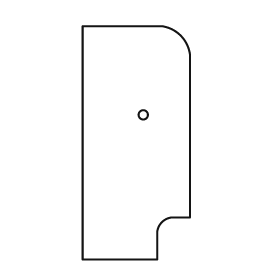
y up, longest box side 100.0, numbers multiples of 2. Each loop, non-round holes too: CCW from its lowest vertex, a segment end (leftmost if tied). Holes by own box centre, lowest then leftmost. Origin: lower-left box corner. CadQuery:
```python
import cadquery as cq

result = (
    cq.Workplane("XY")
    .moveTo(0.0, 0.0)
    .lineTo(32.0, 0.0)
    .lineTo(32.0, 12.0)
    .threePointArc((34.0, 16.0), (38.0, 18.0))
    .lineTo(46.0, 18.0)
    .lineTo(46.0, 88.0)
    .threePointArc((42.0, 96.0), (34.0, 100.0))
    .lineTo(0.0, 100.0)
    .close()
    .moveTo(26.0, 62.0)
    .circle(2.0)
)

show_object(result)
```